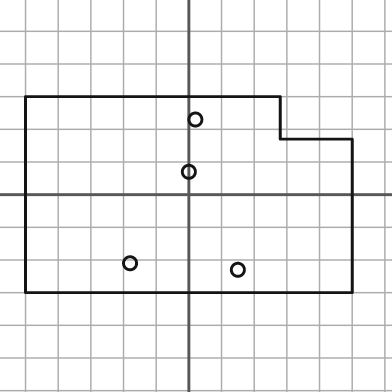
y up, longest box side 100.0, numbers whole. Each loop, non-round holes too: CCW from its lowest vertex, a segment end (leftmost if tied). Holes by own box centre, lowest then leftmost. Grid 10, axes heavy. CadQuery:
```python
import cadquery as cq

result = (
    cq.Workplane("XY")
    .moveTo(-50.0, -30.0)
    .lineTo(50.0, -30.0)
    .lineTo(50.0, 17.0)
    .lineTo(28.0, 17.0)
    .lineTo(28.0, 30.0)
    .lineTo(-50.0, 30.0)
    .close()
    .moveTo(15.0, -23.0)
    .circle(2.0)
    .moveTo(-18.0, -21.0)
    .circle(2.0)
    .moveTo(0.0, 7.0)
    .circle(2.0)
    .moveTo(2.0, 23.0)
    .circle(2.0)
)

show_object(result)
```